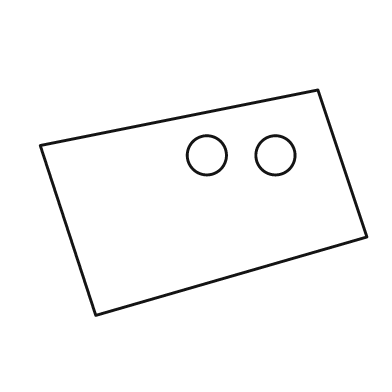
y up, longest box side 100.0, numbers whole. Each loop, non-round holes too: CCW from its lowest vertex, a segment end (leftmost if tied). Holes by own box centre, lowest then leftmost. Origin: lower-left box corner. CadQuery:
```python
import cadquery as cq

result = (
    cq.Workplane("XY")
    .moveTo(17.0, 0.0)
    .lineTo(100.0, 24.0)
    .lineTo(85.0, 69.0)
    .lineTo(0.0, 52.0)
    .close()
    .moveTo(51.0, 49.0)
    .circle(6.0)
    .moveTo(72.0, 49.0)
    .circle(6.0)
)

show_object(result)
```